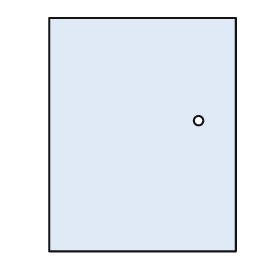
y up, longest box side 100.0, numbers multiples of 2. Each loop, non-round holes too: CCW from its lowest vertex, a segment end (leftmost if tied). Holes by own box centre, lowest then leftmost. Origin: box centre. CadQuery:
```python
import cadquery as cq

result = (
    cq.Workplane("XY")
    .moveTo(-40.0, -50.0)
    .lineTo(40.0, -50.0)
    .lineTo(40.0, 50.0)
    .lineTo(-40.0, 50.0)
    .close()
    .moveTo(24.0, 6.0)
    .circle(2.0)
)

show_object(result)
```